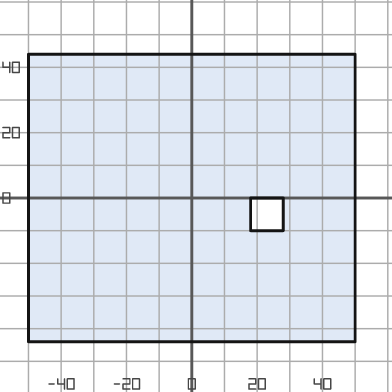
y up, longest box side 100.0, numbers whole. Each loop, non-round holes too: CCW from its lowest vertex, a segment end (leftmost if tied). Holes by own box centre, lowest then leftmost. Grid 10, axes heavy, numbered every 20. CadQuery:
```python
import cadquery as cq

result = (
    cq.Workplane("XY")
    .moveTo(-50.0, -44.0)
    .lineTo(50.0, -44.0)
    .lineTo(50.0, 44.0)
    .lineTo(-50.0, 44.0)
    .close()
    .moveTo(18.0, -10.0)
    .lineTo(28.0, -10.0)
    .lineTo(28.0, 0.0)
    .lineTo(18.0, 0.0)
    .close()
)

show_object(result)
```